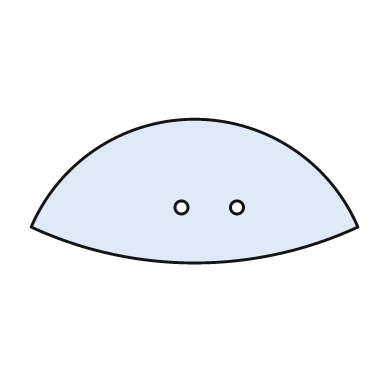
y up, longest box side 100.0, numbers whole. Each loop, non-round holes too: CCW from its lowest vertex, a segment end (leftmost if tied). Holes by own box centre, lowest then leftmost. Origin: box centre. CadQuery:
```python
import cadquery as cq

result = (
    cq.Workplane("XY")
    .moveTo(-50.0, -11.0)
    .threePointArc((0.0, -22.0), (50.0, -11.0))
    .threePointArc((0.0, 22.0), (-50.0, -11.0))
    .close()
    .moveTo(-4.0, -5.0)
    .circle(2.0)
    .moveTo(13.0, -5.0)
    .circle(2.0)
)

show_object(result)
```